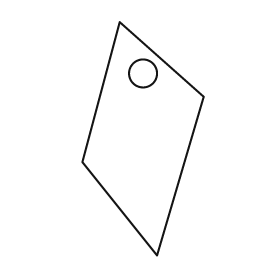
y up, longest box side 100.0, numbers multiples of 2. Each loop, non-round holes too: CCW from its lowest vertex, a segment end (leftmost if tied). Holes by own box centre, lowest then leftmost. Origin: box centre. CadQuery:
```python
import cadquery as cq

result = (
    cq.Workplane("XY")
    .moveTo(6.0, -50.0)
    .lineTo(26.0, 18.0)
    .lineTo(-10.0, 50.0)
    .lineTo(-26.0, -10.0)
    .close()
    .moveTo(0.0, 28.0)
    .circle(6.0)
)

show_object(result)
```